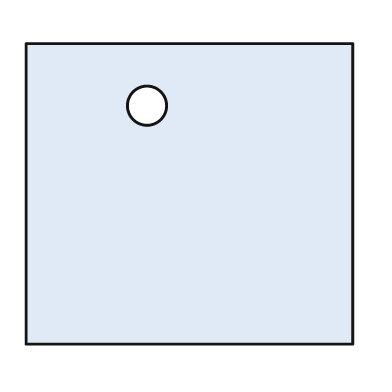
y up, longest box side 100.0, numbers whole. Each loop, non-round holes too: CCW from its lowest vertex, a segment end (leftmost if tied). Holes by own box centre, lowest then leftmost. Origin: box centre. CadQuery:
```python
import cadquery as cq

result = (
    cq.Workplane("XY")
    .moveTo(-50.0, -46.0)
    .lineTo(50.0, -46.0)
    .lineTo(50.0, 46.0)
    .lineTo(-50.0, 46.0)
    .close()
    .moveTo(-13.0, 27.0)
    .circle(6.0)
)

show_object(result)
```